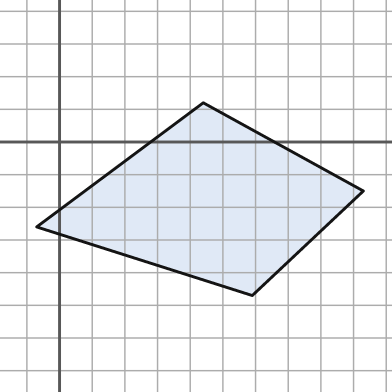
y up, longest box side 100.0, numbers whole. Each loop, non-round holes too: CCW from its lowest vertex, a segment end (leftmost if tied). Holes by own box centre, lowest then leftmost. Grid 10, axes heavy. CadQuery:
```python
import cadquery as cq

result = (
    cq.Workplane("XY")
    .moveTo(59.0, -47.0)
    .lineTo(93.0, -15.0)
    .lineTo(44.0, 12.0)
    .lineTo(-7.0, -26.0)
    .close()
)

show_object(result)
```